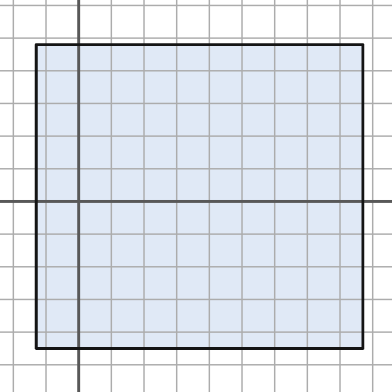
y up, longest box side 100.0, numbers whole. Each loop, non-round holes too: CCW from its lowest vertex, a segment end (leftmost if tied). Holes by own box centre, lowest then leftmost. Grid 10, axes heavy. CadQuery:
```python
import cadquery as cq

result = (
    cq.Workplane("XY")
    .moveTo(-13.0, -45.0)
    .lineTo(87.0, -45.0)
    .lineTo(87.0, 48.0)
    .lineTo(-13.0, 48.0)
    .close()
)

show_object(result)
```